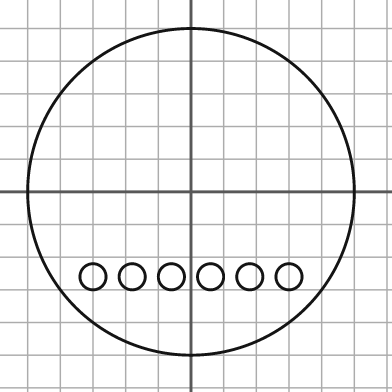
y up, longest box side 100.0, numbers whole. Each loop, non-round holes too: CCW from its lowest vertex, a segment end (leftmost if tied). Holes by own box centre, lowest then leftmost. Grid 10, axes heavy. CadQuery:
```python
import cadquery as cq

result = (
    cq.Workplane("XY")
    .moveTo(0.0, 0.0)
    .circle(50.0)
    .moveTo(-30.0, -26.0)
    .circle(4.0)
    .moveTo(-18.0, -26.0)
    .circle(4.0)
    .moveTo(-6.0, -26.0)
    .circle(4.0)
    .moveTo(6.0, -26.0)
    .circle(4.0)
    .moveTo(18.0, -26.0)
    .circle(4.0)
    .moveTo(30.0, -26.0)
    .circle(4.0)
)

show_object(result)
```